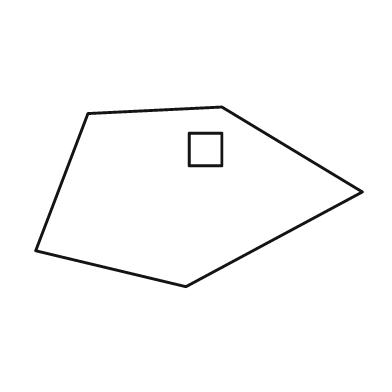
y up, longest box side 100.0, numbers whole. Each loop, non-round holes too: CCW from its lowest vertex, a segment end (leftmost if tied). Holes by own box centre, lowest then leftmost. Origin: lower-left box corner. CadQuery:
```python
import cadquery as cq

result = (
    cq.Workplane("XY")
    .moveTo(46.0, 0.0)
    .lineTo(100.0, 29.0)
    .lineTo(57.0, 55.0)
    .lineTo(16.0, 53.0)
    .lineTo(0.0, 11.0)
    .close()
    .moveTo(47.0, 37.0)
    .lineTo(57.0, 37.0)
    .lineTo(57.0, 47.0)
    .lineTo(47.0, 47.0)
    .close()
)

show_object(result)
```